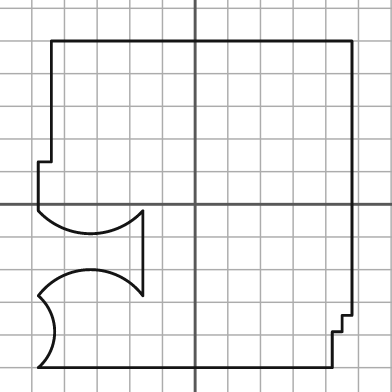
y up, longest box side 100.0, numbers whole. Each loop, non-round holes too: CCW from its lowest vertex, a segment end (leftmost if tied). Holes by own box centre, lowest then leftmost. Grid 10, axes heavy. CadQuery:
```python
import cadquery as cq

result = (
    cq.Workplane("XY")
    .moveTo(-48.0, -50.0)
    .lineTo(42.0, -50.0)
    .lineTo(42.0, -39.0)
    .lineTo(45.0, -39.0)
    .lineTo(45.0, -34.0)
    .lineTo(48.0, -34.0)
    .lineTo(48.0, 50.0)
    .lineTo(-44.0, 50.0)
    .lineTo(-44.0, 13.0)
    .lineTo(-48.0, 13.0)
    .lineTo(-48.0, -2.0)
    .threePointArc((-32.0, -9.0), (-16.0, -2.0))
    .lineTo(-16.0, -28.0)
    .threePointArc((-32.0, -20.0), (-48.0, -28.0))
    .threePointArc((-43.0, -39.0), (-48.0, -50.0))
    .close()
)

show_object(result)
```